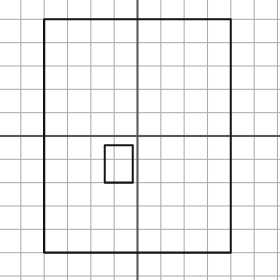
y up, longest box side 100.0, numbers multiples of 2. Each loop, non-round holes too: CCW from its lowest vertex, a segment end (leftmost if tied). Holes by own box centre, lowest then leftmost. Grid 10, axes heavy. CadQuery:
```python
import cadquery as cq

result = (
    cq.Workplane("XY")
    .moveTo(-40.0, -50.0)
    .lineTo(40.0, -50.0)
    .lineTo(40.0, 50.0)
    .lineTo(-40.0, 50.0)
    .close()
    .moveTo(-14.0, -20.0)
    .lineTo(-2.0, -20.0)
    .lineTo(-2.0, -4.0)
    .lineTo(-14.0, -4.0)
    .close()
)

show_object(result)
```